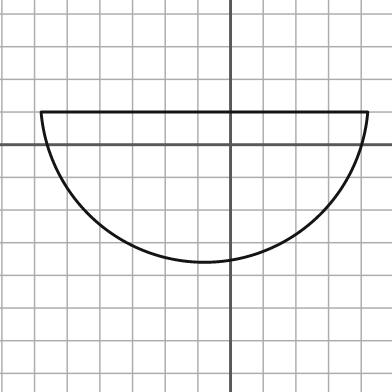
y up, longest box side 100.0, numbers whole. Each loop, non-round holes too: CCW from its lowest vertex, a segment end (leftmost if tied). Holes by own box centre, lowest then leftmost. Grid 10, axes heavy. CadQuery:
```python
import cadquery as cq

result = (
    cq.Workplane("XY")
    .moveTo(-58.0, 10.0)
    .threePointArc((-8.0, -36.0), (42.0, 10.0))
    .close()
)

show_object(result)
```